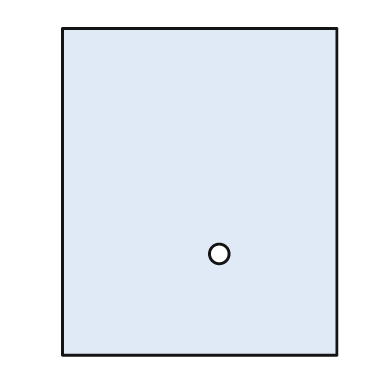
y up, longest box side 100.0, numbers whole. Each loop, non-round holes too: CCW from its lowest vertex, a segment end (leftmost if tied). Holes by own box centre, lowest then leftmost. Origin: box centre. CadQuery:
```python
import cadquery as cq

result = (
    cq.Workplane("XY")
    .moveTo(-42.0, -50.0)
    .lineTo(42.0, -50.0)
    .lineTo(42.0, 50.0)
    .lineTo(-42.0, 50.0)
    .close()
    .moveTo(6.0, -19.0)
    .circle(3.0)
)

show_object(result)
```